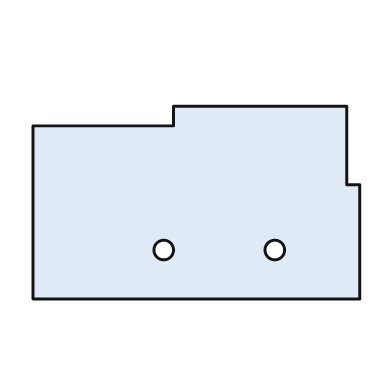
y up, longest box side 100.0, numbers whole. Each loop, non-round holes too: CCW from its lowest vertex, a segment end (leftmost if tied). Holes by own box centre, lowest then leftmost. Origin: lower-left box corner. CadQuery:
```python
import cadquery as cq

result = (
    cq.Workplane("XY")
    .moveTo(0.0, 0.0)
    .lineTo(100.0, 0.0)
    .lineTo(100.0, 35.0)
    .lineTo(96.0, 35.0)
    .lineTo(96.0, 59.0)
    .lineTo(43.0, 59.0)
    .lineTo(43.0, 53.0)
    .lineTo(0.0, 53.0)
    .close()
    .moveTo(40.0, 15.0)
    .circle(3.0)
    .moveTo(74.0, 15.0)
    .circle(3.0)
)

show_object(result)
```